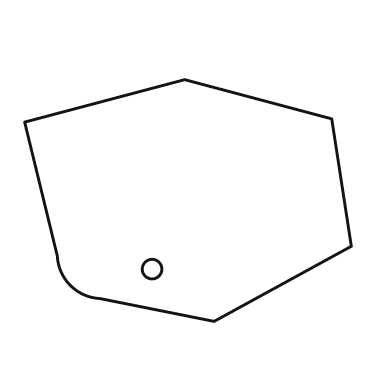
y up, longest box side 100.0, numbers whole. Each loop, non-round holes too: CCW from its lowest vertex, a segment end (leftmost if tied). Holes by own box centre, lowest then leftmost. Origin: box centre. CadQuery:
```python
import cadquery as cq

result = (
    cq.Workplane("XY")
    .moveTo(8.0, -37.0)
    .lineTo(50.0, -14.0)
    .lineTo(44.0, 25.0)
    .lineTo(-1.0, 37.0)
    .lineTo(-50.0, 24.0)
    .lineTo(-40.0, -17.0)
    .threePointArc((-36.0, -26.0), (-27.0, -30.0))
    .close()
    .moveTo(-11.0, -21.0)
    .circle(3.0)
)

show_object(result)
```